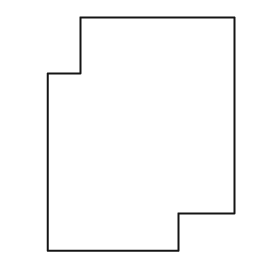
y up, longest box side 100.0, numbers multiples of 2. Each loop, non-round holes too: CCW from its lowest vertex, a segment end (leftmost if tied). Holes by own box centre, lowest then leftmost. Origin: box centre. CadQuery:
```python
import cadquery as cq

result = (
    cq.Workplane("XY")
    .moveTo(-40.0, -50.0)
    .lineTo(16.0, -50.0)
    .lineTo(16.0, -34.0)
    .lineTo(40.0, -34.0)
    .lineTo(40.0, 50.0)
    .lineTo(-26.0, 50.0)
    .lineTo(-26.0, 26.0)
    .lineTo(-40.0, 26.0)
    .close()
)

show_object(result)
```